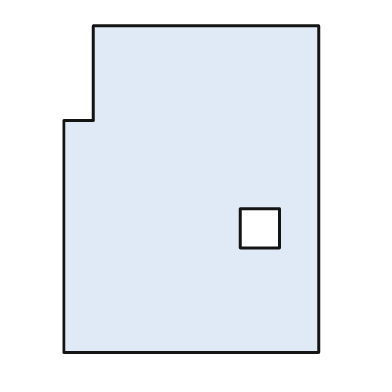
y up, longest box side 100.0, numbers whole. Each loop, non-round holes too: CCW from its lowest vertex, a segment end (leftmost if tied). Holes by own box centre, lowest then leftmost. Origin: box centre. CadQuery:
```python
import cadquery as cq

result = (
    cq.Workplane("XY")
    .moveTo(-39.0, -50.0)
    .lineTo(39.0, -50.0)
    .lineTo(39.0, 50.0)
    .lineTo(-30.0, 50.0)
    .lineTo(-30.0, 21.0)
    .lineTo(-39.0, 21.0)
    .close()
    .moveTo(15.0, -18.0)
    .lineTo(27.0, -18.0)
    .lineTo(27.0, -6.0)
    .lineTo(15.0, -6.0)
    .close()
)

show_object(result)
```